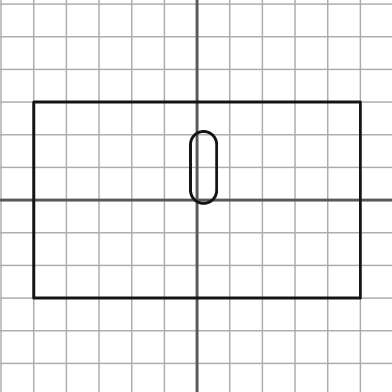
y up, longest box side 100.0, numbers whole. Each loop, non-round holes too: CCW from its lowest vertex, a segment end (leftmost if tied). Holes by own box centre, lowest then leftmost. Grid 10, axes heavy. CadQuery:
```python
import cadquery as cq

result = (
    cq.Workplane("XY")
    .moveTo(-50.0, -30.0)
    .lineTo(50.0, -30.0)
    .lineTo(50.0, 30.0)
    .lineTo(-50.0, 30.0)
    .close()
    .moveTo(-2.0, 3.0)
    .threePointArc((2.0, -1.0), (6.0, 3.0))
    .lineTo(6.0, 17.0)
    .threePointArc((2.0, 21.0), (-2.0, 17.0))
    .close()
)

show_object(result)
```